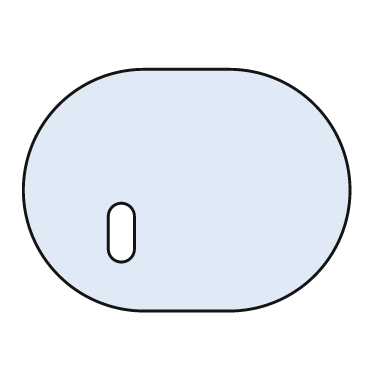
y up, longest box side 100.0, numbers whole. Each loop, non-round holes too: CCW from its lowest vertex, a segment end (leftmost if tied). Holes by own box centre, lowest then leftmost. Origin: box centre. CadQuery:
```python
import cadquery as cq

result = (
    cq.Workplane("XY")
    .moveTo(-13.0, -37.0)
    .lineTo(13.0, -37.0)
    .threePointArc((50.0, 0.0), (13.0, 37.0))
    .lineTo(-13.0, 37.0)
    .threePointArc((-50.0, 0.0), (-13.0, -37.0))
    .close()
    .moveTo(-24.0, -18.0)
    .threePointArc((-20.0, -22.0), (-16.0, -18.0))
    .lineTo(-16.0, -8.0)
    .threePointArc((-20.0, -4.0), (-24.0, -8.0))
    .close()
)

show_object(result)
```